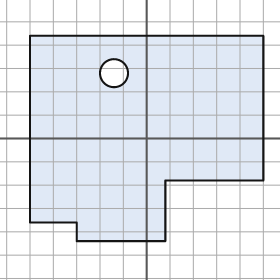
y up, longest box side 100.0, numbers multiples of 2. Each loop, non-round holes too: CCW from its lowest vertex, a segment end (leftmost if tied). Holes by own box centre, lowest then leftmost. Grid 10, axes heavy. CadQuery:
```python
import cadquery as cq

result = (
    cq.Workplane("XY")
    .moveTo(-30.0, -44.0)
    .lineTo(8.0, -44.0)
    .lineTo(8.0, -18.0)
    .lineTo(50.0, -18.0)
    .lineTo(50.0, 44.0)
    .lineTo(-50.0, 44.0)
    .lineTo(-50.0, -36.0)
    .lineTo(-30.0, -36.0)
    .close()
    .moveTo(-14.0, 28.0)
    .circle(6.0)
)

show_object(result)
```